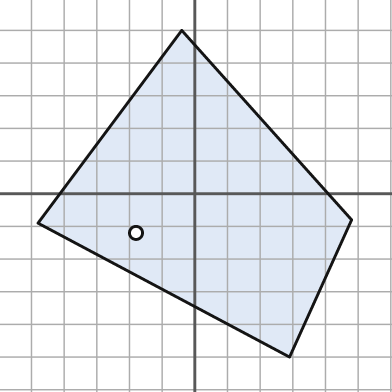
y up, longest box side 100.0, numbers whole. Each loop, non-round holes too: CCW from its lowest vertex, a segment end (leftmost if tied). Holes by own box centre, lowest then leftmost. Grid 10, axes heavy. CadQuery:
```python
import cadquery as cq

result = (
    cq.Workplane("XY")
    .moveTo(29.0, -50.0)
    .lineTo(48.0, -8.0)
    .lineTo(-4.0, 50.0)
    .lineTo(-48.0, -9.0)
    .close()
    .moveTo(-18.0, -12.0)
    .circle(2.0)
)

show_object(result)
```